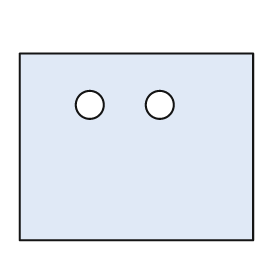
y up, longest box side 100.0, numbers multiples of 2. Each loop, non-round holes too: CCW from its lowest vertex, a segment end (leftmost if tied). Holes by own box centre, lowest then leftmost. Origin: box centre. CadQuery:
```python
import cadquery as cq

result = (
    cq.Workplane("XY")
    .moveTo(-50.0, -40.0)
    .lineTo(50.0, -40.0)
    .lineTo(50.0, 40.0)
    .lineTo(-50.0, 40.0)
    .close()
    .moveTo(-20.0, 18.0)
    .circle(6.0)
    .moveTo(10.0, 18.0)
    .circle(6.0)
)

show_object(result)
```